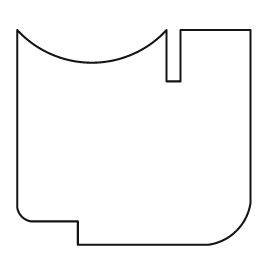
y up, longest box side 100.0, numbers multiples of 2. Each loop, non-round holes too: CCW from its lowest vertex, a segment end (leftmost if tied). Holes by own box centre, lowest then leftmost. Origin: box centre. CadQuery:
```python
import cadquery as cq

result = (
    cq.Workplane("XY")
    .moveTo(-24.0, -46.0)
    .lineTo(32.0, -46.0)
    .threePointArc((44.0, -40.0), (50.0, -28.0))
    .lineTo(50.0, 46.0)
    .lineTo(20.0, 46.0)
    .lineTo(20.0, 24.0)
    .lineTo(14.0, 24.0)
    .lineTo(14.0, 46.0)
    .threePointArc((-18.0, 32.0), (-50.0, 46.0))
    .lineTo(-50.0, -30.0)
    .threePointArc((-48.0, -34.0), (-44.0, -36.0))
    .lineTo(-24.0, -36.0)
    .close()
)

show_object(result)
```